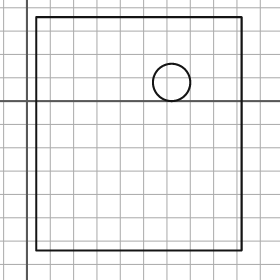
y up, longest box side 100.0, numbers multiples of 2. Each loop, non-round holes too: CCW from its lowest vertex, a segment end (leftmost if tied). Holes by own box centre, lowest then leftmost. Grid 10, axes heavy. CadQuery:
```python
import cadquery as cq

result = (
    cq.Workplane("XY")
    .moveTo(4.0, -64.0)
    .lineTo(92.0, -64.0)
    .lineTo(92.0, 36.0)
    .lineTo(4.0, 36.0)
    .close()
    .moveTo(62.0, 8.0)
    .circle(8.0)
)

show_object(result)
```